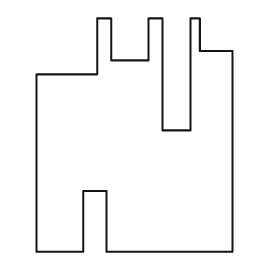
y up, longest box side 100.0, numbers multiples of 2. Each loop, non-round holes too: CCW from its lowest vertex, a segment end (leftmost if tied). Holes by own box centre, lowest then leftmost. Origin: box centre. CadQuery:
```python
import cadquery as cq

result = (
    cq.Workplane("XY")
    .moveTo(-42.0, -50.0)
    .lineTo(-22.0, -50.0)
    .lineTo(-22.0, -24.0)
    .lineTo(-12.0, -24.0)
    .lineTo(-12.0, -50.0)
    .lineTo(42.0, -50.0)
    .lineTo(42.0, 36.0)
    .lineTo(28.0, 36.0)
    .lineTo(28.0, 50.0)
    .lineTo(24.0, 50.0)
    .lineTo(24.0, 2.0)
    .lineTo(12.0, 2.0)
    .lineTo(12.0, 50.0)
    .lineTo(6.0, 50.0)
    .lineTo(6.0, 32.0)
    .lineTo(-10.0, 32.0)
    .lineTo(-10.0, 50.0)
    .lineTo(-16.0, 50.0)
    .lineTo(-16.0, 26.0)
    .lineTo(-42.0, 26.0)
    .close()
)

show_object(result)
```